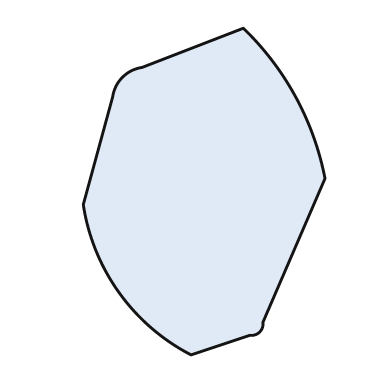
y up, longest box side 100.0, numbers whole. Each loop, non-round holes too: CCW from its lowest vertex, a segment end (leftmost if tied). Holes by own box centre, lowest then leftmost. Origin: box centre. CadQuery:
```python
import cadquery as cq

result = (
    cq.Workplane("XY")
    .moveTo(-4.0, -50.0)
    .lineTo(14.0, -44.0)
    .threePointArc((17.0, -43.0), (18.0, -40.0))
    .lineTo(37.0, 4.0)
    .threePointArc((28.0, 29.0), (12.0, 50.0))
    .lineTo(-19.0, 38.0)
    .threePointArc((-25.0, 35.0), (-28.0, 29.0))
    .lineTo(-37.0, -4.0)
    .threePointArc((-26.0, -31.0), (-4.0, -50.0))
    .close()
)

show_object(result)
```